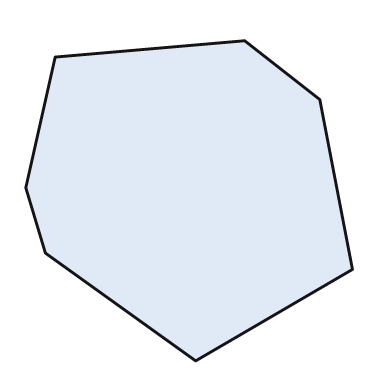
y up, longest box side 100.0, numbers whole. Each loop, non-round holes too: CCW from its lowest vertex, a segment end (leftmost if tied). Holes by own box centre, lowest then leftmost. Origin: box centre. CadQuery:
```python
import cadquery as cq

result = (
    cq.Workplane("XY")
    .moveTo(2.0, -49.0)
    .lineTo(50.0, -21.0)
    .lineTo(40.0, 31.0)
    .lineTo(17.0, 49.0)
    .lineTo(-41.0, 44.0)
    .lineTo(-50.0, 4.0)
    .lineTo(-44.0, -16.0)
    .close()
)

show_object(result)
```